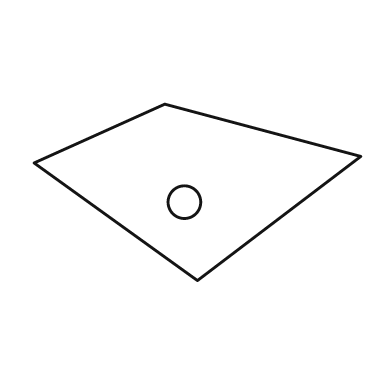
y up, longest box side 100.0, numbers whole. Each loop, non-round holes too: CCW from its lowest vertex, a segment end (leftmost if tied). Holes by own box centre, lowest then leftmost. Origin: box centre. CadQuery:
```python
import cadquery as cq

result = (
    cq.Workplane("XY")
    .moveTo(0.0, -27.0)
    .lineTo(50.0, 11.0)
    .lineTo(-10.0, 27.0)
    .lineTo(-50.0, 9.0)
    .close()
    .moveTo(-4.0, -3.0)
    .circle(5.0)
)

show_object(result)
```